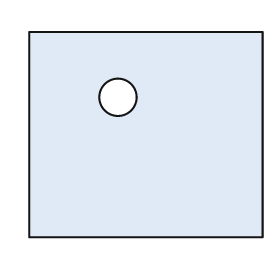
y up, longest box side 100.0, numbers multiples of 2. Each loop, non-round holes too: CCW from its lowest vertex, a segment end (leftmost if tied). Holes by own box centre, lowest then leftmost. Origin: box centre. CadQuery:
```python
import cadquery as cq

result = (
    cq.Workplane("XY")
    .moveTo(-50.0, -44.0)
    .lineTo(50.0, -44.0)
    .lineTo(50.0, 44.0)
    .lineTo(-50.0, 44.0)
    .close()
    .moveTo(-12.0, 16.0)
    .circle(8.0)
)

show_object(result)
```